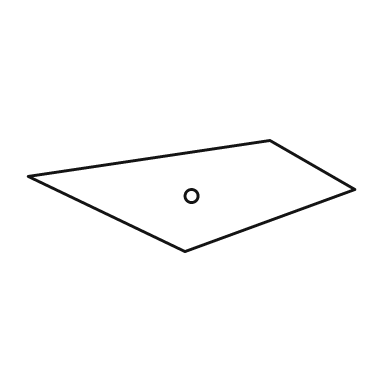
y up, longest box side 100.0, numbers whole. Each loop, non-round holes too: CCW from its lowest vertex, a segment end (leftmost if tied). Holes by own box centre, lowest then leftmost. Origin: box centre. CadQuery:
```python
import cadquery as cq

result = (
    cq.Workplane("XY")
    .moveTo(-2.0, -17.0)
    .lineTo(50.0, 2.0)
    .lineTo(24.0, 17.0)
    .lineTo(-50.0, 6.0)
    .close()
    .moveTo(0.0, 0.0)
    .circle(2.0)
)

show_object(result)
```